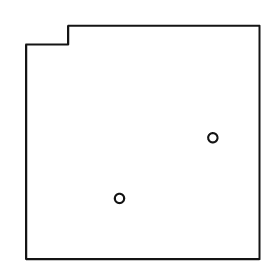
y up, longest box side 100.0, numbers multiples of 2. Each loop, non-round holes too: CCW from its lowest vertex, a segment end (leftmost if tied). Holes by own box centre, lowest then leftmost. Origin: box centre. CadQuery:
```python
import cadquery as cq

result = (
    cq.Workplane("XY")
    .moveTo(-50.0, -50.0)
    .lineTo(50.0, -50.0)
    .lineTo(50.0, 50.0)
    .lineTo(-32.0, 50.0)
    .lineTo(-32.0, 42.0)
    .lineTo(-50.0, 42.0)
    .close()
    .moveTo(-10.0, -24.0)
    .circle(2.0)
    .moveTo(30.0, 2.0)
    .circle(2.0)
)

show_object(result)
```